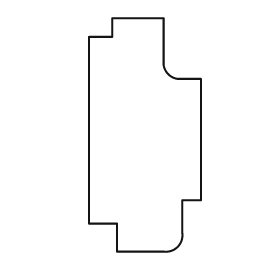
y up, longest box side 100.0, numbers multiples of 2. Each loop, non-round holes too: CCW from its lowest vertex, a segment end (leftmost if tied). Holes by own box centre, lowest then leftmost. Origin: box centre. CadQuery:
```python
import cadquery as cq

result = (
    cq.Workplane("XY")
    .moveTo(-12.0, -50.0)
    .lineTo(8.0, -50.0)
    .threePointArc((14.0, -48.0), (16.0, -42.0))
    .lineTo(16.0, -28.0)
    .lineTo(24.0, -28.0)
    .lineTo(24.0, 24.0)
    .lineTo(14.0, 24.0)
    .threePointArc((10.0, 26.0), (8.0, 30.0))
    .lineTo(8.0, 50.0)
    .lineTo(-14.0, 50.0)
    .lineTo(-14.0, 42.0)
    .lineTo(-24.0, 42.0)
    .lineTo(-24.0, -38.0)
    .lineTo(-12.0, -38.0)
    .close()
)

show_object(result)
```